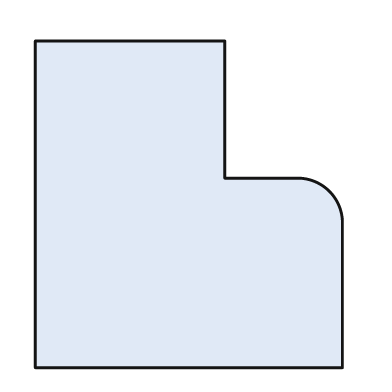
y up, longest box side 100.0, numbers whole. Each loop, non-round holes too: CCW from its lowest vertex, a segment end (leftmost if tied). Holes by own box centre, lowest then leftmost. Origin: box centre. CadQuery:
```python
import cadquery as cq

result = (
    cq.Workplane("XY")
    .moveTo(-47.0, -50.0)
    .lineTo(47.0, -50.0)
    .lineTo(47.0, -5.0)
    .threePointArc((43.0, 4.0), (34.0, 8.0))
    .lineTo(11.0, 8.0)
    .lineTo(11.0, 50.0)
    .lineTo(-47.0, 50.0)
    .close()
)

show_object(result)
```